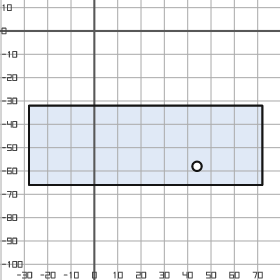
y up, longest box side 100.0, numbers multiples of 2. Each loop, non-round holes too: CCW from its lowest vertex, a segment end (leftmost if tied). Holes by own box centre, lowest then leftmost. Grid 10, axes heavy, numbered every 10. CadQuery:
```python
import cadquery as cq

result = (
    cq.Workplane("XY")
    .moveTo(-28.0, -66.0)
    .lineTo(72.0, -66.0)
    .lineTo(72.0, -32.0)
    .lineTo(-28.0, -32.0)
    .close()
    .moveTo(44.0, -58.0)
    .circle(2.0)
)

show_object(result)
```